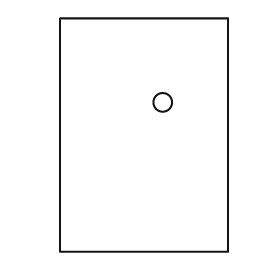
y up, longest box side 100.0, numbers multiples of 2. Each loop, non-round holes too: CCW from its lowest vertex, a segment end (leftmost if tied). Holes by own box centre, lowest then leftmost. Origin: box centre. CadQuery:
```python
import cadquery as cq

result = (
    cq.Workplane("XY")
    .moveTo(-36.0, -50.0)
    .lineTo(36.0, -50.0)
    .lineTo(36.0, 50.0)
    .lineTo(-36.0, 50.0)
    .close()
    .moveTo(8.0, 14.0)
    .circle(4.0)
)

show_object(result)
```